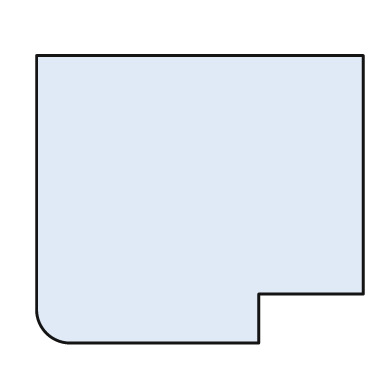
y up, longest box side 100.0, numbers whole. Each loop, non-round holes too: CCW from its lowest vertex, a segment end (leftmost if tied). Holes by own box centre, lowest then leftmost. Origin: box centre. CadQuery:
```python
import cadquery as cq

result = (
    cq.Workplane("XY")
    .moveTo(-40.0, -44.0)
    .lineTo(18.0, -44.0)
    .lineTo(18.0, -29.0)
    .lineTo(50.0, -29.0)
    .lineTo(50.0, 44.0)
    .lineTo(-50.0, 44.0)
    .lineTo(-50.0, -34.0)
    .threePointArc((-47.0, -41.0), (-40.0, -44.0))
    .close()
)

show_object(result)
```